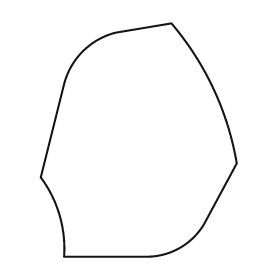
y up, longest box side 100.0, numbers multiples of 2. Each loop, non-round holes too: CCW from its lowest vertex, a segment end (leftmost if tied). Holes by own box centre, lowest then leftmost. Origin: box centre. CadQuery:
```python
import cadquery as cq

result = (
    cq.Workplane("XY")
    .moveTo(-32.0, -50.0)
    .lineTo(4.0, -50.0)
    .threePointArc((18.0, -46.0), (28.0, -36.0))
    .lineTo(42.0, -10.0)
    .threePointArc((32.0, 22.0), (14.0, 50.0))
    .lineTo(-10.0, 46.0)
    .threePointArc((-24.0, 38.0), (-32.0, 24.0))
    .lineTo(-42.0, -16.0)
    .threePointArc((-34.0, -32.0), (-32.0, -50.0))
    .close()
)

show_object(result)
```